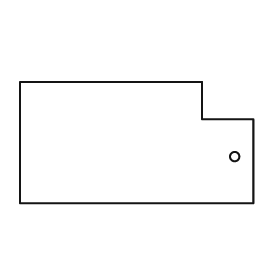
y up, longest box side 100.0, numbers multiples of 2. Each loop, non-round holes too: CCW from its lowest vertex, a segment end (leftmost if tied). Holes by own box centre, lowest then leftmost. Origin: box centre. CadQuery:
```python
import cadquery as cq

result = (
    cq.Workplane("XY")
    .moveTo(-50.0, -26.0)
    .lineTo(50.0, -26.0)
    .lineTo(50.0, 10.0)
    .lineTo(28.0, 10.0)
    .lineTo(28.0, 26.0)
    .lineTo(-50.0, 26.0)
    .close()
    .moveTo(42.0, -6.0)
    .circle(2.0)
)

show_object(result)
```